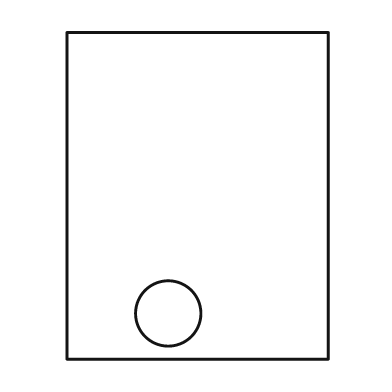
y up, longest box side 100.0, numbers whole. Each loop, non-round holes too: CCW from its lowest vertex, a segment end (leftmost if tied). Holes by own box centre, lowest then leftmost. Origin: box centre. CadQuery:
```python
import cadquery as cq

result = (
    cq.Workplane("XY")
    .moveTo(-40.0, -50.0)
    .lineTo(40.0, -50.0)
    .lineTo(40.0, 50.0)
    .lineTo(-40.0, 50.0)
    .close()
    .moveTo(-9.0, -36.0)
    .circle(10.0)
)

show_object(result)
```